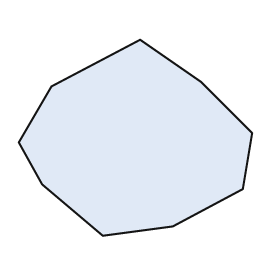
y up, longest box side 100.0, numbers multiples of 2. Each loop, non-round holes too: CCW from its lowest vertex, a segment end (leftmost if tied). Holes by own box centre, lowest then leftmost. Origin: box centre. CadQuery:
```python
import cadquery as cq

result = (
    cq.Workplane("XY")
    .moveTo(-14.0, -42.0)
    .lineTo(16.0, -38.0)
    .lineTo(46.0, -22.0)
    .lineTo(50.0, 2.0)
    .lineTo(28.0, 24.0)
    .lineTo(2.0, 42.0)
    .lineTo(-36.0, 22.0)
    .lineTo(-50.0, -2.0)
    .lineTo(-40.0, -20.0)
    .close()
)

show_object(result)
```